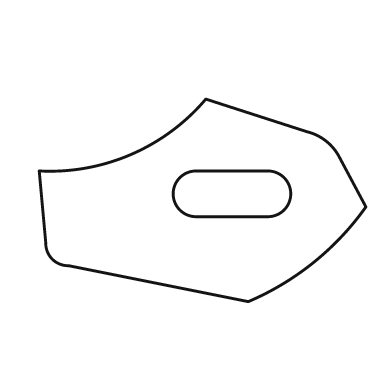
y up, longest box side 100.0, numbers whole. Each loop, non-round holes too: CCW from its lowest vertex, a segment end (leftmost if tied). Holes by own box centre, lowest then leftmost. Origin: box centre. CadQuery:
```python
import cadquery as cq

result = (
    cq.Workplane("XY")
    .moveTo(14.0, -31.0)
    .threePointArc((34.0, -19.0), (50.0, -2.0))
    .lineTo(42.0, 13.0)
    .threePointArc((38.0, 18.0), (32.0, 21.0))
    .lineTo(1.0, 31.0)
    .threePointArc((-22.0, 14.0), (-50.0, 9.0))
    .lineTo(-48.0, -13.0)
    .threePointArc((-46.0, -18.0), (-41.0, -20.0))
    .close()
    .moveTo(-2.0, -5.0)
    .lineTo(20.0, -5.0)
    .threePointArc((27.0, 2.0), (20.0, 9.0))
    .lineTo(-2.0, 9.0)
    .threePointArc((-9.0, 2.0), (-2.0, -5.0))
    .close()
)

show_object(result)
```